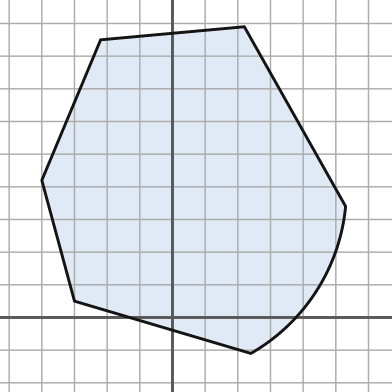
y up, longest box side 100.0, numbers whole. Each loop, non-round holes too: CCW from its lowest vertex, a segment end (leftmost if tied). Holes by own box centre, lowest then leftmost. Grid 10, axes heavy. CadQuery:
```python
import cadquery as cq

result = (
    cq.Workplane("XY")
    .moveTo(24.0, -11.0)
    .threePointArc((44.0, 8.0), (53.0, 34.0))
    .lineTo(22.0, 89.0)
    .lineTo(-22.0, 85.0)
    .lineTo(-40.0, 42.0)
    .lineTo(-30.0, 5.0)
    .close()
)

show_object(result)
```